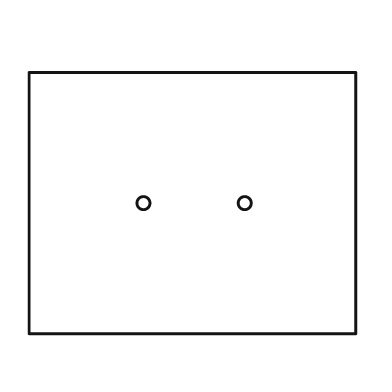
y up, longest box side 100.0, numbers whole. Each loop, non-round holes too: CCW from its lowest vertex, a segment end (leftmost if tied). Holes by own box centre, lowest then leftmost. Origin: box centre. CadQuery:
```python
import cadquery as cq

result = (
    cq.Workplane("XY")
    .moveTo(-50.0, -40.0)
    .lineTo(50.0, -40.0)
    .lineTo(50.0, 40.0)
    .lineTo(-50.0, 40.0)
    .close()
    .moveTo(-15.0, 0.0)
    .circle(2.0)
    .moveTo(16.0, 0.0)
    .circle(2.0)
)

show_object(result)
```